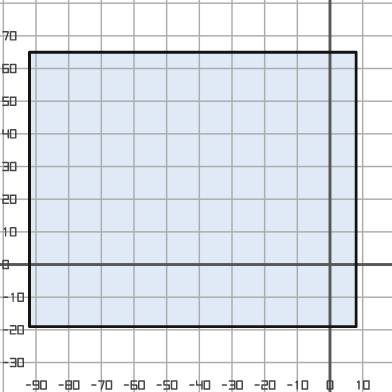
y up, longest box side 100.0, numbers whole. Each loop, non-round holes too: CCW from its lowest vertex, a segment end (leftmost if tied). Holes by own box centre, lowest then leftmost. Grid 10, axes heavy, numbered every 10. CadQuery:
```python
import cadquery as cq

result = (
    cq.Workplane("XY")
    .moveTo(-92.0, -19.0)
    .lineTo(8.0, -19.0)
    .lineTo(8.0, 65.0)
    .lineTo(-92.0, 65.0)
    .close()
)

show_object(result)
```